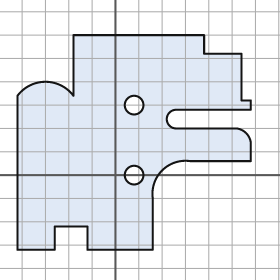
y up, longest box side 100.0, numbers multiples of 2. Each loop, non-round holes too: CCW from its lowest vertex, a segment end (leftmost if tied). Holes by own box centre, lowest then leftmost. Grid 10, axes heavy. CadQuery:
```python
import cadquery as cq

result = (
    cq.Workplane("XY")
    .moveTo(-42.0, -32.0)
    .lineTo(-26.0, -32.0)
    .lineTo(-26.0, -22.0)
    .lineTo(-12.0, -22.0)
    .lineTo(-12.0, -32.0)
    .lineTo(16.0, -32.0)
    .lineTo(16.0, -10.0)
    .threePointArc((20.0, 2.0), (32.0, 6.0))
    .lineTo(58.0, 6.0)
    .lineTo(58.0, 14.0)
    .threePointArc((56.0, 18.0), (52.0, 20.0))
    .lineTo(26.0, 20.0)
    .threePointArc((22.0, 24.0), (26.0, 28.0))
    .lineTo(58.0, 28.0)
    .lineTo(58.0, 32.0)
    .lineTo(54.0, 32.0)
    .lineTo(54.0, 52.0)
    .lineTo(38.0, 52.0)
    .lineTo(38.0, 60.0)
    .lineTo(-18.0, 60.0)
    .lineTo(-18.0, 34.0)
    .threePointArc((-30.0, 40.0), (-42.0, 34.0))
    .close()
    .moveTo(8.0, 0.0)
    .circle(4.0)
    .moveTo(8.0, 30.0)
    .circle(4.0)
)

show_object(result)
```